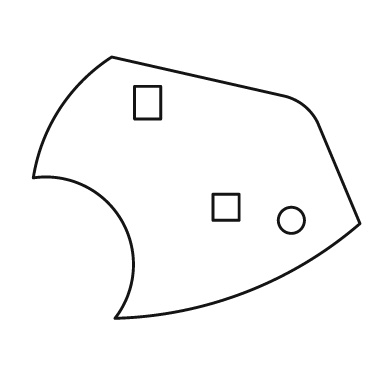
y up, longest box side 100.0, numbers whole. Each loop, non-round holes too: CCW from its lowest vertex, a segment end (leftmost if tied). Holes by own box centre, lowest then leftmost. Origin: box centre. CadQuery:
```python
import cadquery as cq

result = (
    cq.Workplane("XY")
    .moveTo(-25.0, -40.0)
    .threePointArc((15.0, -32.0), (50.0, -11.0))
    .lineTo(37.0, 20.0)
    .threePointArc((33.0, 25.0), (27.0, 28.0))
    .lineTo(-26.0, 40.0)
    .threePointArc((-42.0, 24.0), (-50.0, 3.0))
    .threePointArc((-23.0, -10.0), (-25.0, -40.0))
    .close()
    .moveTo(29.0, -10.0)
    .circle(4.0)
    .moveTo(5.0, -10.0)
    .lineTo(13.0, -10.0)
    .lineTo(13.0, -2.0)
    .lineTo(5.0, -2.0)
    .close()
    .moveTo(-19.0, 21.0)
    .lineTo(-11.0, 21.0)
    .lineTo(-11.0, 31.0)
    .lineTo(-19.0, 31.0)
    .close()
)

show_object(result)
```